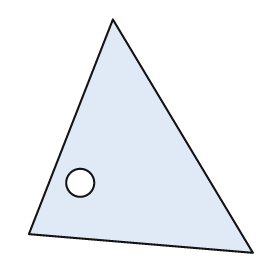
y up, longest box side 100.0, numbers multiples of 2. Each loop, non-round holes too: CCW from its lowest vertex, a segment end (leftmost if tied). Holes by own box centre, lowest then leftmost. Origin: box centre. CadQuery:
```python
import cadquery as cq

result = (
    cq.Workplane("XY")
    .moveTo(48.0, -50.0)
    .lineTo(-12.0, 50.0)
    .lineTo(-48.0, -42.0)
    .close()
    .moveTo(-26.0, -20.0)
    .circle(6.0)
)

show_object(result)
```